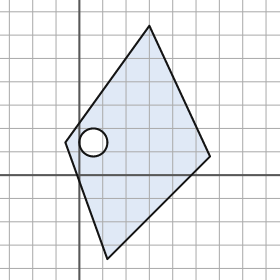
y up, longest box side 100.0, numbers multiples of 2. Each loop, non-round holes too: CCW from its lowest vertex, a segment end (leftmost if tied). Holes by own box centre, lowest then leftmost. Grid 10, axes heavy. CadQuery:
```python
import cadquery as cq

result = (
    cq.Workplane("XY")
    .moveTo(12.0, -36.0)
    .lineTo(56.0, 8.0)
    .lineTo(30.0, 64.0)
    .lineTo(-6.0, 14.0)
    .close()
    .moveTo(6.0, 14.0)
    .circle(6.0)
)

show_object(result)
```